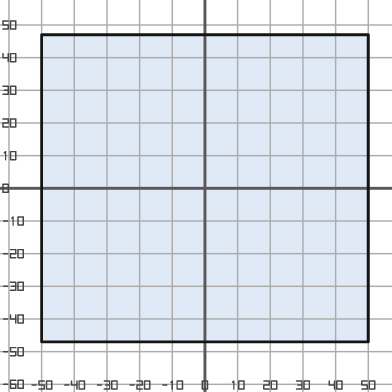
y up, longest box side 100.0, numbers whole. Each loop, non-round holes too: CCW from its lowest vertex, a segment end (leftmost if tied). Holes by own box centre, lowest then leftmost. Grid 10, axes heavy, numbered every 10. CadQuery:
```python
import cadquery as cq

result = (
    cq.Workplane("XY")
    .moveTo(-50.0, -47.0)
    .lineTo(50.0, -47.0)
    .lineTo(50.0, 47.0)
    .lineTo(-50.0, 47.0)
    .close()
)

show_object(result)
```